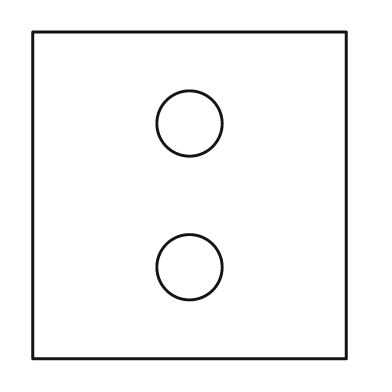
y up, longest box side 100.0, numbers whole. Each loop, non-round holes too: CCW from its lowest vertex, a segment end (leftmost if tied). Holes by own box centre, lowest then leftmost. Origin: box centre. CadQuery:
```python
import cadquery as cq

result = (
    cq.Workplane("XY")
    .moveTo(-48.0, -50.0)
    .lineTo(48.0, -50.0)
    .lineTo(48.0, 50.0)
    .lineTo(-48.0, 50.0)
    .close()
    .moveTo(0.0, -22.0)
    .circle(10.0)
    .moveTo(0.0, 22.0)
    .circle(10.0)
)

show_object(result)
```